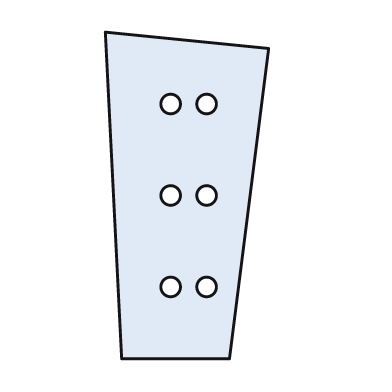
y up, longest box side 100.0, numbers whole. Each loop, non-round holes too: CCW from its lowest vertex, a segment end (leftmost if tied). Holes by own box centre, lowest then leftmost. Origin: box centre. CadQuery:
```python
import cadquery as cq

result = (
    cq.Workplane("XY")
    .moveTo(-20.0, -50.0)
    .lineTo(13.0, -50.0)
    .lineTo(25.0, 45.0)
    .lineTo(-25.0, 50.0)
    .close()
    .moveTo(-5.0, -28.0)
    .circle(3.0)
    .moveTo(6.0, -28.0)
    .circle(3.0)
    .moveTo(-5.0, 0.0)
    .circle(3.0)
    .moveTo(6.0, 0.0)
    .circle(3.0)
    .moveTo(-5.0, 28.0)
    .circle(3.0)
    .moveTo(6.0, 28.0)
    .circle(3.0)
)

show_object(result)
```